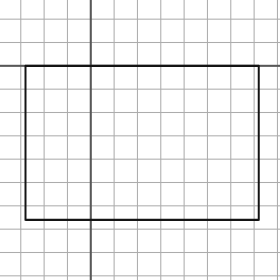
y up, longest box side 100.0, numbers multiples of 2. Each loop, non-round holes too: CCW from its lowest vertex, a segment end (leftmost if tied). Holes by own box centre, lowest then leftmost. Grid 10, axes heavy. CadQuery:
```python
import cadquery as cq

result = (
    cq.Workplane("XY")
    .moveTo(-28.0, -66.0)
    .lineTo(72.0, -66.0)
    .lineTo(72.0, 0.0)
    .lineTo(-28.0, 0.0)
    .close()
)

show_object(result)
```